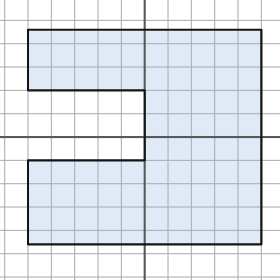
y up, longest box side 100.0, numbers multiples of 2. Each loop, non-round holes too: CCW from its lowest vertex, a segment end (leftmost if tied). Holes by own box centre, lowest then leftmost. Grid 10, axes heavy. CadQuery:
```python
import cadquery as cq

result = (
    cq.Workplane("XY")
    .moveTo(-50.0, -46.0)
    .lineTo(50.0, -46.0)
    .lineTo(50.0, 46.0)
    .lineTo(-50.0, 46.0)
    .lineTo(-50.0, 20.0)
    .lineTo(0.0, 20.0)
    .lineTo(0.0, -10.0)
    .lineTo(-50.0, -10.0)
    .close()
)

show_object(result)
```